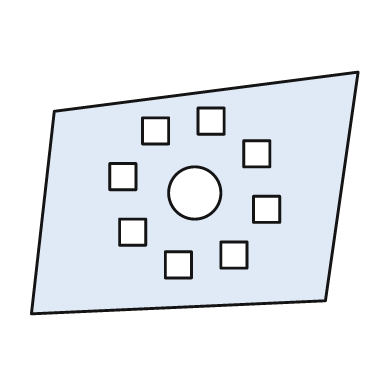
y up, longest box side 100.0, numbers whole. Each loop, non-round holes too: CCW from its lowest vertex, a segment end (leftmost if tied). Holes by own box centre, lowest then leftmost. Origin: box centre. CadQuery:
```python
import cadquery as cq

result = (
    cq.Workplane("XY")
    .moveTo(-50.0, -37.0)
    .lineTo(40.0, -33.0)
    .lineTo(50.0, 37.0)
    .lineTo(-43.0, 25.0)
    .close()
    .moveTo(-9.0, -26.0)
    .lineTo(-1.0, -26.0)
    .lineTo(-1.0, -18.0)
    .lineTo(-9.0, -18.0)
    .close()
    .moveTo(8.0, -23.0)
    .lineTo(16.0, -23.0)
    .lineTo(16.0, -15.0)
    .lineTo(8.0, -15.0)
    .close()
    .moveTo(-23.0, -16.0)
    .lineTo(-15.0, -16.0)
    .lineTo(-15.0, -8.0)
    .lineTo(-23.0, -8.0)
    .close()
    .moveTo(18.0, -9.0)
    .lineTo(26.0, -9.0)
    .lineTo(26.0, -1.0)
    .lineTo(18.0, -1.0)
    .close()
    .moveTo(0.0, 0.0)
    .circle(8.0)
    .moveTo(-26.0, 1.0)
    .lineTo(-18.0, 1.0)
    .lineTo(-18.0, 9.0)
    .lineTo(-26.0, 9.0)
    .close()
    .moveTo(15.0, 8.0)
    .lineTo(23.0, 8.0)
    .lineTo(23.0, 16.0)
    .lineTo(15.0, 16.0)
    .close()
    .moveTo(-16.0, 15.0)
    .lineTo(-8.0, 15.0)
    .lineTo(-8.0, 23.0)
    .lineTo(-16.0, 23.0)
    .close()
    .moveTo(1.0, 18.0)
    .lineTo(9.0, 18.0)
    .lineTo(9.0, 26.0)
    .lineTo(1.0, 26.0)
    .close()
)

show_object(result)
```